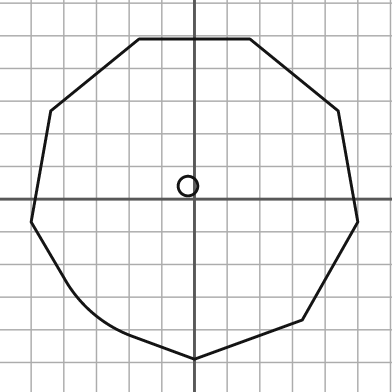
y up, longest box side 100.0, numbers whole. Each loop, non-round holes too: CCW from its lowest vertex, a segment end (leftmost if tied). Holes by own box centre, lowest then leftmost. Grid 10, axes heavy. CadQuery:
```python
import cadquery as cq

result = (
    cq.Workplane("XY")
    .moveTo(0.0, -49.0)
    .lineTo(33.0, -37.0)
    .lineTo(50.0, -7.0)
    .lineTo(44.0, 27.0)
    .lineTo(17.0, 49.0)
    .lineTo(-17.0, 49.0)
    .lineTo(-44.0, 27.0)
    .lineTo(-50.0, -7.0)
    .lineTo(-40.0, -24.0)
    .threePointArc((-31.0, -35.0), (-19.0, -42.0))
    .close()
    .moveTo(-2.0, 4.0)
    .circle(3.0)
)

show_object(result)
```